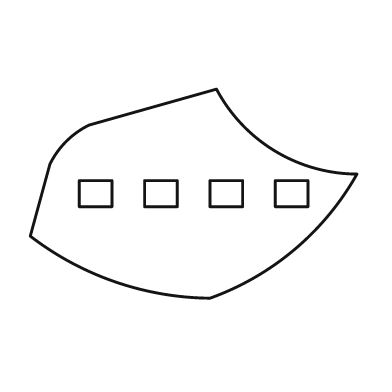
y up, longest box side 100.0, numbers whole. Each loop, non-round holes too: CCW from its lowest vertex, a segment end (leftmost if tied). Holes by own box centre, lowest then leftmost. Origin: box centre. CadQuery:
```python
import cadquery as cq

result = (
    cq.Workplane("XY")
    .moveTo(5.0, -32.0)
    .threePointArc((31.0, -17.0), (50.0, 6.0))
    .threePointArc((25.0, 13.0), (7.0, 32.0))
    .lineTo(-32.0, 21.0)
    .threePointArc((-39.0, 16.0), (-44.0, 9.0))
    .lineTo(-50.0, -13.0)
    .threePointArc((-24.0, -27.0), (5.0, -32.0))
    .close()
    .moveTo(-35.0, -4.0)
    .lineTo(-25.0, -4.0)
    .lineTo(-25.0, 4.0)
    .lineTo(-35.0, 4.0)
    .close()
    .moveTo(-15.0, -4.0)
    .lineTo(-5.0, -4.0)
    .lineTo(-5.0, 4.0)
    .lineTo(-15.0, 4.0)
    .close()
    .moveTo(5.0, -4.0)
    .lineTo(15.0, -4.0)
    .lineTo(15.0, 4.0)
    .lineTo(5.0, 4.0)
    .close()
    .moveTo(25.0, -4.0)
    .lineTo(35.0, -4.0)
    .lineTo(35.0, 4.0)
    .lineTo(25.0, 4.0)
    .close()
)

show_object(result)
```